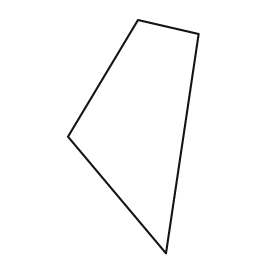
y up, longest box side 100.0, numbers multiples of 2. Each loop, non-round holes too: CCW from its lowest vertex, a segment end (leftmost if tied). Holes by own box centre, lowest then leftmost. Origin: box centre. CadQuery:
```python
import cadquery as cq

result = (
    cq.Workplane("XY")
    .moveTo(14.0, -50.0)
    .lineTo(28.0, 44.0)
    .lineTo(2.0, 50.0)
    .lineTo(-28.0, 0.0)
    .close()
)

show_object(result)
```